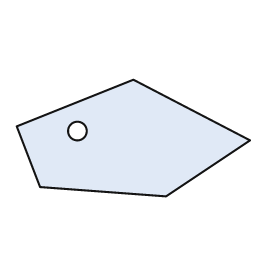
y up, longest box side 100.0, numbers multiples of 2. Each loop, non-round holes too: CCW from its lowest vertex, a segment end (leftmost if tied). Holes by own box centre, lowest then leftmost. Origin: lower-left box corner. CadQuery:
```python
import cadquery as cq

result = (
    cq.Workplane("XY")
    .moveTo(64.0, 0.0)
    .lineTo(100.0, 24.0)
    .lineTo(50.0, 50.0)
    .lineTo(0.0, 30.0)
    .lineTo(10.0, 4.0)
    .close()
    .moveTo(26.0, 28.0)
    .circle(4.0)
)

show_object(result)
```